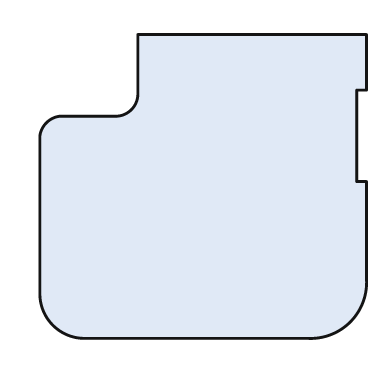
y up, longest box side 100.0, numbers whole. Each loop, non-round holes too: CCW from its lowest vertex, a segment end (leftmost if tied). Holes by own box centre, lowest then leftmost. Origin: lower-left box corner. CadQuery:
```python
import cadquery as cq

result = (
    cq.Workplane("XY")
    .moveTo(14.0, 0.0)
    .lineTo(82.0, 0.0)
    .threePointArc((95.0, 5.0), (100.0, 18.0))
    .lineTo(100.0, 48.0)
    .lineTo(97.0, 48.0)
    .lineTo(97.0, 76.0)
    .lineTo(100.0, 76.0)
    .lineTo(100.0, 93.0)
    .lineTo(30.0, 93.0)
    .lineTo(30.0, 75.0)
    .threePointArc((28.0, 70.0), (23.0, 68.0))
    .lineTo(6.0, 68.0)
    .threePointArc((2.0, 66.0), (0.0, 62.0))
    .lineTo(0.0, 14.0)
    .threePointArc((4.0, 4.0), (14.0, 0.0))
    .close()
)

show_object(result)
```